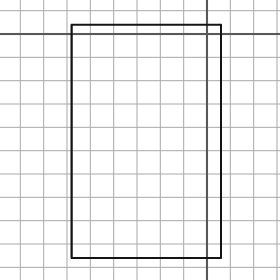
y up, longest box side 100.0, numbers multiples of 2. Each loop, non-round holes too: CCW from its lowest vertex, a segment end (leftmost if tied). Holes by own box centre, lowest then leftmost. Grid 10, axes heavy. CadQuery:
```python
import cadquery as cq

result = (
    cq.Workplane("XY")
    .moveTo(-58.0, -96.0)
    .lineTo(6.0, -96.0)
    .lineTo(6.0, 4.0)
    .lineTo(-58.0, 4.0)
    .close()
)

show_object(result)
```